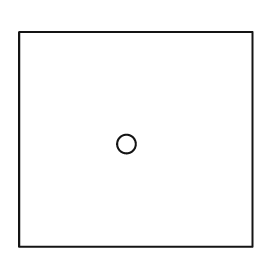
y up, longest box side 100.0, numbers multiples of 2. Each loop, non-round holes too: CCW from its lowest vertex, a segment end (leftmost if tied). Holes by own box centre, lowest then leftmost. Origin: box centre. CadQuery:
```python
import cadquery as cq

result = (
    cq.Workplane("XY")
    .moveTo(-50.0, -46.0)
    .lineTo(50.0, -46.0)
    .lineTo(50.0, 46.0)
    .lineTo(-50.0, 46.0)
    .close()
    .moveTo(-4.0, -2.0)
    .circle(4.0)
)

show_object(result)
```